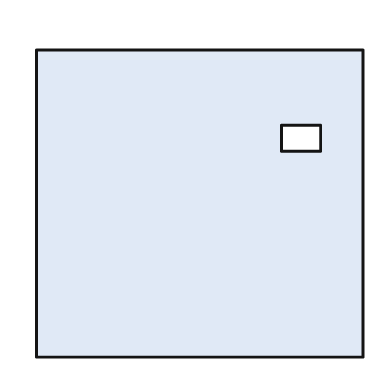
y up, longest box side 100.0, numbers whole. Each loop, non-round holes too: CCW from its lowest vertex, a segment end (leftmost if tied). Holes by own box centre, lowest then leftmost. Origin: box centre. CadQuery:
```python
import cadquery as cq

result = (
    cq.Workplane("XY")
    .moveTo(-50.0, -47.0)
    .lineTo(50.0, -47.0)
    .lineTo(50.0, 47.0)
    .lineTo(-50.0, 47.0)
    .close()
    .moveTo(25.0, 16.0)
    .lineTo(37.0, 16.0)
    .lineTo(37.0, 24.0)
    .lineTo(25.0, 24.0)
    .close()
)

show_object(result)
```